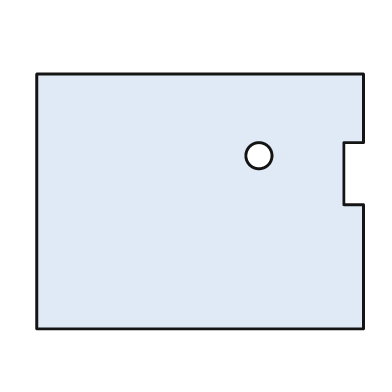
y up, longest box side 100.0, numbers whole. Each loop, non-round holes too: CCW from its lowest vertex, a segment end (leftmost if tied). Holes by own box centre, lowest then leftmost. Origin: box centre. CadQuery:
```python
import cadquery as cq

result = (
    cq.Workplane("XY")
    .moveTo(-50.0, -39.0)
    .lineTo(50.0, -39.0)
    .lineTo(50.0, -1.0)
    .lineTo(44.0, -1.0)
    .lineTo(44.0, 18.0)
    .lineTo(50.0, 18.0)
    .lineTo(50.0, 39.0)
    .lineTo(-50.0, 39.0)
    .close()
    .moveTo(18.0, 14.0)
    .circle(4.0)
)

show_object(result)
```